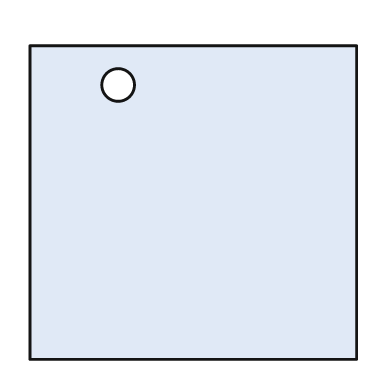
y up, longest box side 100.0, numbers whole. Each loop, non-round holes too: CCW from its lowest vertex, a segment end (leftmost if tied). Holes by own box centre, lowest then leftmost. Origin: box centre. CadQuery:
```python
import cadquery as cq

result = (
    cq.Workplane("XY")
    .moveTo(-50.0, -48.0)
    .lineTo(50.0, -48.0)
    .lineTo(50.0, 48.0)
    .lineTo(-50.0, 48.0)
    .close()
    .moveTo(-23.0, 36.0)
    .circle(5.0)
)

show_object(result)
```